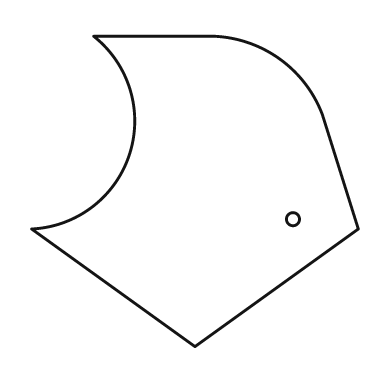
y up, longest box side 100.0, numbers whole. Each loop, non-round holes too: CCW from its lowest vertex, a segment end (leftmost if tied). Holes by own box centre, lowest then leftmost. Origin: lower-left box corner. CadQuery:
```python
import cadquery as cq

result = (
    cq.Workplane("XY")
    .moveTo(50.0, 0.0)
    .lineTo(100.0, 36.0)
    .lineTo(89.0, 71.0)
    .threePointArc((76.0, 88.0), (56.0, 95.0))
    .lineTo(19.0, 95.0)
    .threePointArc((30.0, 59.0), (0.0, 36.0))
    .close()
    .moveTo(80.0, 39.0)
    .circle(2.0)
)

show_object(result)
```